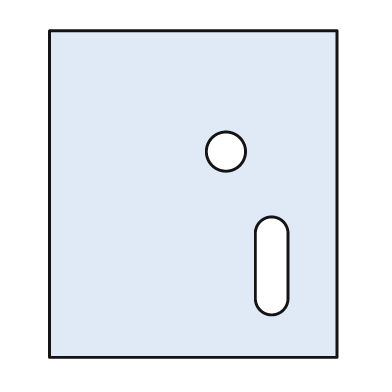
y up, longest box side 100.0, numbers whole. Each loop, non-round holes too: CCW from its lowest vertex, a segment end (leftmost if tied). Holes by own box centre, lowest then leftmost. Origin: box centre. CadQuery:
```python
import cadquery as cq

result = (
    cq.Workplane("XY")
    .moveTo(-44.0, -50.0)
    .lineTo(44.0, -50.0)
    .lineTo(44.0, 50.0)
    .lineTo(-44.0, 50.0)
    .close()
    .moveTo(19.0, -32.0)
    .threePointArc((24.0, -37.0), (29.0, -32.0))
    .lineTo(29.0, -12.0)
    .threePointArc((24.0, -7.0), (19.0, -12.0))
    .close()
    .moveTo(10.0, 13.0)
    .circle(6.0)
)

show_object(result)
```